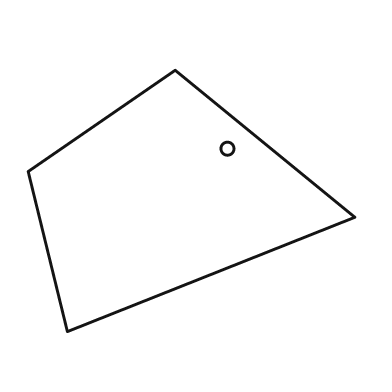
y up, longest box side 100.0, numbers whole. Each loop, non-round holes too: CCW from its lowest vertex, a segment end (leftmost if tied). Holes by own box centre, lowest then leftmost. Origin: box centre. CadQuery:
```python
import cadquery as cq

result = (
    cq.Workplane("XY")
    .moveTo(-38.0, -40.0)
    .lineTo(50.0, -5.0)
    .lineTo(-5.0, 40.0)
    .lineTo(-50.0, 9.0)
    .close()
    .moveTo(11.0, 16.0)
    .circle(2.0)
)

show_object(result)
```